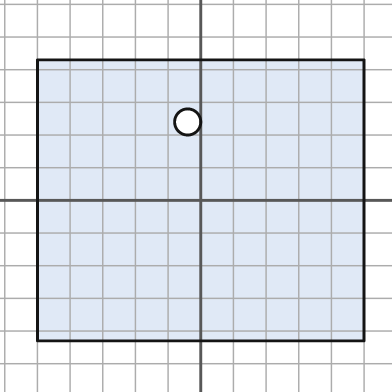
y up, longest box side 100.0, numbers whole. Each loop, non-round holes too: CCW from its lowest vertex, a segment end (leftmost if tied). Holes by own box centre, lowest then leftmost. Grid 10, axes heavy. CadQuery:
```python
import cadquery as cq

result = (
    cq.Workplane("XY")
    .moveTo(-50.0, -43.0)
    .lineTo(50.0, -43.0)
    .lineTo(50.0, 43.0)
    .lineTo(-50.0, 43.0)
    .close()
    .moveTo(-4.0, 24.0)
    .circle(4.0)
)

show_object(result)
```